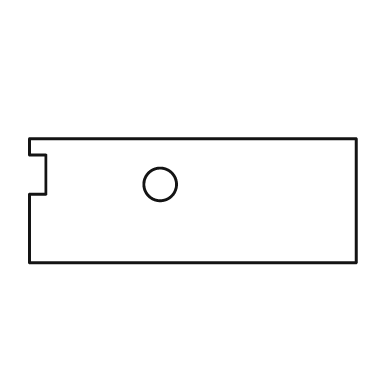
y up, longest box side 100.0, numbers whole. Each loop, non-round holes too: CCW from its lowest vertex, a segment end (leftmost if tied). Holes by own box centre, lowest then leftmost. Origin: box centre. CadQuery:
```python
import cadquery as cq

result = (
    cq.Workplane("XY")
    .moveTo(-50.0, -19.0)
    .lineTo(50.0, -19.0)
    .lineTo(50.0, 19.0)
    .lineTo(-50.0, 19.0)
    .lineTo(-50.0, 14.0)
    .lineTo(-45.0, 14.0)
    .lineTo(-45.0, 2.0)
    .lineTo(-50.0, 2.0)
    .close()
    .moveTo(-10.0, 5.0)
    .circle(5.0)
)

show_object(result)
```